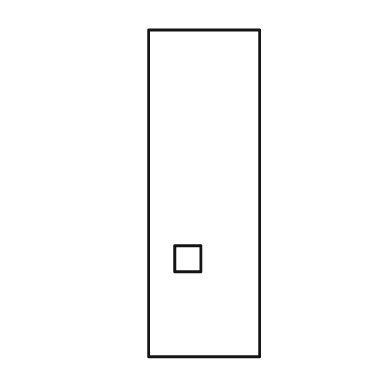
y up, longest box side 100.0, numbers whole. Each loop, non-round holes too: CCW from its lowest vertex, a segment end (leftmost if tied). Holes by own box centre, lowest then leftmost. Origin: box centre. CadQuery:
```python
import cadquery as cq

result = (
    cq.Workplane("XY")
    .moveTo(-17.0, -50.0)
    .lineTo(17.0, -50.0)
    .lineTo(17.0, 50.0)
    .lineTo(-17.0, 50.0)
    .close()
    .moveTo(-9.0, -24.0)
    .lineTo(-1.0, -24.0)
    .lineTo(-1.0, -16.0)
    .lineTo(-9.0, -16.0)
    .close()
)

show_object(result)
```